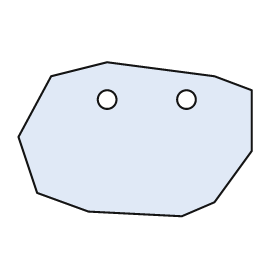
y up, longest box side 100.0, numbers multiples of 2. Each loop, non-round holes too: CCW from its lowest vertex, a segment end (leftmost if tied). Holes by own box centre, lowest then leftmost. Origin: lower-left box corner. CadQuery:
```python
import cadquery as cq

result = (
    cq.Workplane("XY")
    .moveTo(70.0, 0.0)
    .lineTo(84.0, 6.0)
    .lineTo(100.0, 28.0)
    .lineTo(100.0, 54.0)
    .lineTo(84.0, 60.0)
    .lineTo(38.0, 66.0)
    .lineTo(14.0, 60.0)
    .lineTo(0.0, 34.0)
    .lineTo(8.0, 10.0)
    .lineTo(30.0, 2.0)
    .close()
    .moveTo(38.0, 50.0)
    .circle(4.0)
    .moveTo(72.0, 50.0)
    .circle(4.0)
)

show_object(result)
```